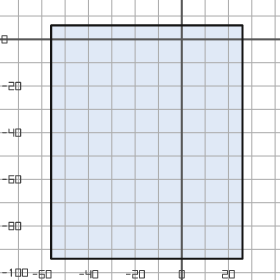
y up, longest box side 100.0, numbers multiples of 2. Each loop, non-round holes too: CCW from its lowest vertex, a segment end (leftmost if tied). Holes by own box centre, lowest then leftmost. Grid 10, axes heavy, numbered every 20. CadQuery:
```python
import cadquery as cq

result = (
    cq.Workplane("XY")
    .moveTo(-56.0, -94.0)
    .lineTo(26.0, -94.0)
    .lineTo(26.0, 6.0)
    .lineTo(-56.0, 6.0)
    .close()
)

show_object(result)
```